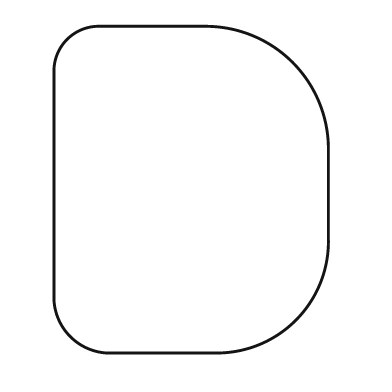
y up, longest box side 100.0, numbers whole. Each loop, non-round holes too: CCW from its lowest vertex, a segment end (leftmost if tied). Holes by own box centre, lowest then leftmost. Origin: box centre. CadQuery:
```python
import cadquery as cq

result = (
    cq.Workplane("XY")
    .moveTo(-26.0, -50.0)
    .lineTo(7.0, -50.0)
    .threePointArc((32.0, -40.0), (42.0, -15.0))
    .lineTo(42.0, 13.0)
    .threePointArc((31.0, 39.0), (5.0, 50.0))
    .lineTo(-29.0, 50.0)
    .threePointArc((-38.0, 46.0), (-42.0, 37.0))
    .lineTo(-42.0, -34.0)
    .threePointArc((-37.0, -45.0), (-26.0, -50.0))
    .close()
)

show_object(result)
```